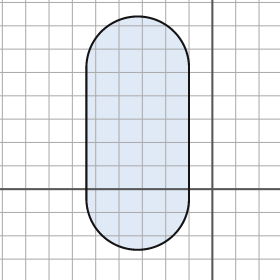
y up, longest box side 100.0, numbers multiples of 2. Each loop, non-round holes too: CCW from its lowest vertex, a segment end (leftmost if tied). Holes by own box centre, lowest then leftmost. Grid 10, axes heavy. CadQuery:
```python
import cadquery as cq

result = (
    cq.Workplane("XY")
    .moveTo(-54.0, -4.0)
    .threePointArc((-32.0, -26.0), (-10.0, -4.0))
    .lineTo(-10.0, 52.0)
    .threePointArc((-32.0, 74.0), (-54.0, 52.0))
    .close()
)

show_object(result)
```